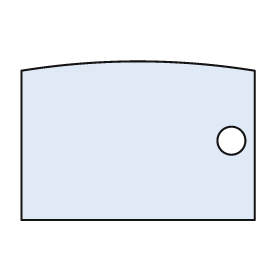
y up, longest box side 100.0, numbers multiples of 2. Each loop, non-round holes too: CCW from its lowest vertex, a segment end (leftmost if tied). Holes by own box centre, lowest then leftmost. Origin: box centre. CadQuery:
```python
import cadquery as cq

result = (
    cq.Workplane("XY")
    .moveTo(-50.0, -34.0)
    .lineTo(50.0, -34.0)
    .lineTo(50.0, 30.0)
    .threePointArc((0.0, 34.0), (-50.0, 30.0))
    .close()
    .moveTo(40.0, 0.0)
    .circle(6.0)
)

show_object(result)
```